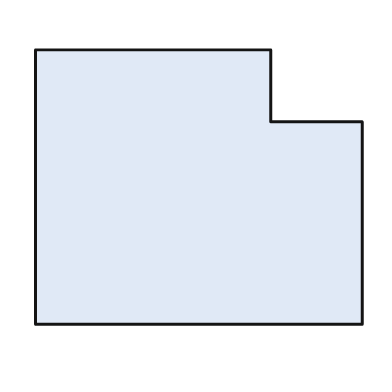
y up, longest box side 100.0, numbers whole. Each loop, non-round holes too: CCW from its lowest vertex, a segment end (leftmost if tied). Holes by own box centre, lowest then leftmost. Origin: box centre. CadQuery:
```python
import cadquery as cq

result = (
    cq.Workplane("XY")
    .moveTo(-50.0, -42.0)
    .lineTo(50.0, -42.0)
    .lineTo(50.0, 20.0)
    .lineTo(22.0, 20.0)
    .lineTo(22.0, 42.0)
    .lineTo(-50.0, 42.0)
    .close()
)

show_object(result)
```